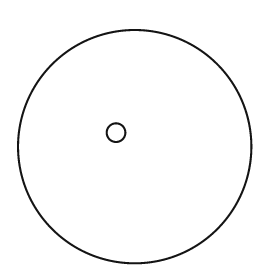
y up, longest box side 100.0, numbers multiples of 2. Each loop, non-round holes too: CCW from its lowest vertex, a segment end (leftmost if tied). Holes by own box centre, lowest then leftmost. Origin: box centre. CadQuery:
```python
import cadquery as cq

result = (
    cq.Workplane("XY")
    .moveTo(0.0, 0.0)
    .circle(50.0)
    .moveTo(-8.0, 6.0)
    .circle(4.0)
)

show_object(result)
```